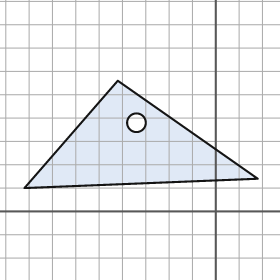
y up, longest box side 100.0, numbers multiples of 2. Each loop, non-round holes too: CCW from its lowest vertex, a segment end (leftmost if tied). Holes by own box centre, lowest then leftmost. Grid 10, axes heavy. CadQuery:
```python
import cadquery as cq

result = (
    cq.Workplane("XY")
    .moveTo(-82.0, 10.0)
    .lineTo(18.0, 14.0)
    .lineTo(-42.0, 56.0)
    .close()
    .moveTo(-34.0, 38.0)
    .circle(4.0)
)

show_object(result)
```